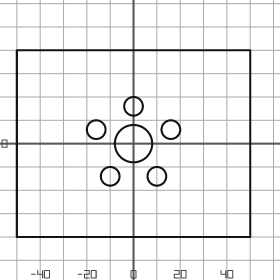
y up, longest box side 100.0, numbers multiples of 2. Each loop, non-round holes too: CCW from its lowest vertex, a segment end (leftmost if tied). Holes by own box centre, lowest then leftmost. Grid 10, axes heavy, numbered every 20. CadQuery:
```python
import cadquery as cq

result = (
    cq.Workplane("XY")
    .moveTo(-50.0, -40.0)
    .lineTo(50.0, -40.0)
    .lineTo(50.0, 40.0)
    .lineTo(-50.0, 40.0)
    .close()
    .moveTo(-10.0, -14.0)
    .circle(4.0)
    .moveTo(10.0, -14.0)
    .circle(4.0)
    .moveTo(0.0, 0.0)
    .circle(8.0)
    .moveTo(-16.0, 6.0)
    .circle(4.0)
    .moveTo(16.0, 6.0)
    .circle(4.0)
    .moveTo(0.0, 16.0)
    .circle(4.0)
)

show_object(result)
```